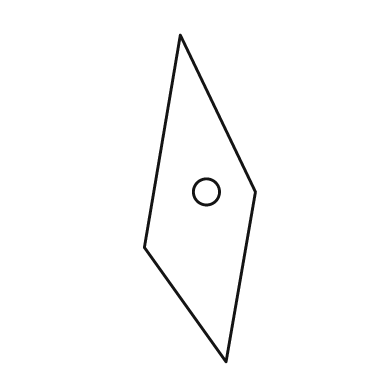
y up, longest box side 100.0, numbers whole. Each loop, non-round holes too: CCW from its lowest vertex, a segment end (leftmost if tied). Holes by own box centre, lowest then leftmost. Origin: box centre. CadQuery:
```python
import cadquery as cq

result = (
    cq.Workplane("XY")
    .moveTo(8.0, -50.0)
    .lineTo(17.0, 2.0)
    .lineTo(-6.0, 50.0)
    .lineTo(-17.0, -15.0)
    .close()
    .moveTo(2.0, 2.0)
    .circle(4.0)
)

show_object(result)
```